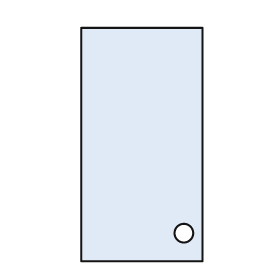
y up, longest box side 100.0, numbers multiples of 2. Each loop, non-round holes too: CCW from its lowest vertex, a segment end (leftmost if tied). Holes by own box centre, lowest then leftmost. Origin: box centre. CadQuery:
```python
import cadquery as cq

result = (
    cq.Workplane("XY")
    .moveTo(-26.0, -50.0)
    .lineTo(26.0, -50.0)
    .lineTo(26.0, 50.0)
    .lineTo(-26.0, 50.0)
    .close()
    .moveTo(18.0, -38.0)
    .circle(4.0)
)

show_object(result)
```